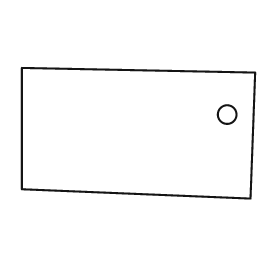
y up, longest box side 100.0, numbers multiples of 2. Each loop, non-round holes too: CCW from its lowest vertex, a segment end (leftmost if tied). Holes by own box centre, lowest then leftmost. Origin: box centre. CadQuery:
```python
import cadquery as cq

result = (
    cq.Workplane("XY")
    .moveTo(48.0, -28.0)
    .lineTo(50.0, 26.0)
    .lineTo(-50.0, 28.0)
    .lineTo(-50.0, -24.0)
    .close()
    .moveTo(38.0, 8.0)
    .circle(4.0)
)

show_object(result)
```